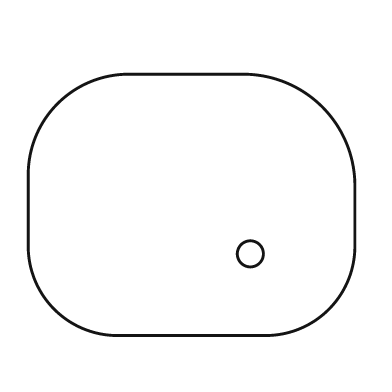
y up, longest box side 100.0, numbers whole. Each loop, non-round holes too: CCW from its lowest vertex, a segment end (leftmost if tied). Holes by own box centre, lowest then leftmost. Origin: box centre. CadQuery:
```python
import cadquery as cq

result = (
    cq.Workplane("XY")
    .moveTo(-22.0, -40.0)
    .lineTo(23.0, -40.0)
    .threePointArc((42.0, -32.0), (50.0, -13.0))
    .lineTo(50.0, 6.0)
    .threePointArc((40.0, 30.0), (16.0, 40.0))
    .lineTo(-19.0, 40.0)
    .threePointArc((-41.0, 31.0), (-50.0, 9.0))
    .lineTo(-50.0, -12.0)
    .threePointArc((-42.0, -32.0), (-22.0, -40.0))
    .close()
    .moveTo(18.0, -15.0)
    .circle(4.0)
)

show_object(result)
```